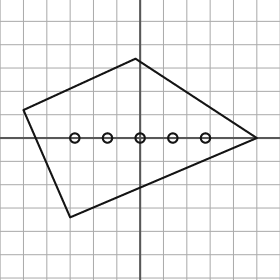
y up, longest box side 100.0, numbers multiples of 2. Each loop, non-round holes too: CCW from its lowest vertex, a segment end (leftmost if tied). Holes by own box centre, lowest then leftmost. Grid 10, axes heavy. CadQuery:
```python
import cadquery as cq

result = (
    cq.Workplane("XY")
    .moveTo(-30.0, -34.0)
    .lineTo(50.0, 0.0)
    .lineTo(-2.0, 34.0)
    .lineTo(-50.0, 12.0)
    .close()
    .moveTo(-28.0, 0.0)
    .circle(2.0)
    .moveTo(-14.0, 0.0)
    .circle(2.0)
    .moveTo(0.0, 0.0)
    .circle(2.0)
    .moveTo(14.0, 0.0)
    .circle(2.0)
    .moveTo(28.0, 0.0)
    .circle(2.0)
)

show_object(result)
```